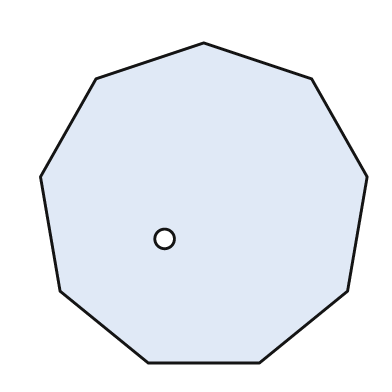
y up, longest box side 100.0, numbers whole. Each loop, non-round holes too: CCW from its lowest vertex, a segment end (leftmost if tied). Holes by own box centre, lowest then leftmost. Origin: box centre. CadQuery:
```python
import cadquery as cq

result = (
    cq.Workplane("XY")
    .moveTo(-17.0, -49.0)
    .lineTo(17.0, -49.0)
    .lineTo(44.0, -27.0)
    .lineTo(50.0, 8.0)
    .lineTo(33.0, 38.0)
    .lineTo(0.0, 49.0)
    .lineTo(-33.0, 38.0)
    .lineTo(-50.0, 8.0)
    .lineTo(-44.0, -27.0)
    .close()
    .moveTo(-12.0, -11.0)
    .circle(3.0)
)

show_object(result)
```